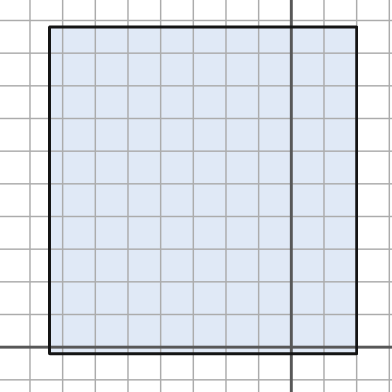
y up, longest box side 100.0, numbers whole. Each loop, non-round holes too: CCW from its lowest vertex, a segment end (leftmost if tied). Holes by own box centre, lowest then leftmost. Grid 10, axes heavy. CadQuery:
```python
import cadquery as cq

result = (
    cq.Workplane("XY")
    .moveTo(-74.0, -2.0)
    .lineTo(20.0, -2.0)
    .lineTo(20.0, 98.0)
    .lineTo(-74.0, 98.0)
    .close()
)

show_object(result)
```